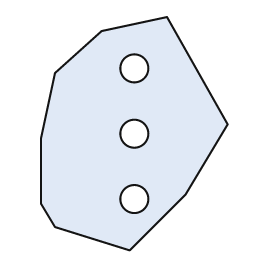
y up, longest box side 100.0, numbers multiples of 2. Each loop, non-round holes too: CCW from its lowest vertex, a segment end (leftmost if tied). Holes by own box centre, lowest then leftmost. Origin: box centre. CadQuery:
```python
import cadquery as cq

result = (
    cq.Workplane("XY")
    .moveTo(-2.0, -50.0)
    .lineTo(22.0, -26.0)
    .lineTo(40.0, 4.0)
    .lineTo(14.0, 50.0)
    .lineTo(-14.0, 44.0)
    .lineTo(-34.0, 26.0)
    .lineTo(-40.0, -2.0)
    .lineTo(-40.0, -30.0)
    .lineTo(-34.0, -40.0)
    .close()
    .moveTo(0.0, -28.0)
    .circle(6.0)
    .moveTo(0.0, 0.0)
    .circle(6.0)
    .moveTo(0.0, 28.0)
    .circle(6.0)
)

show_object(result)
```